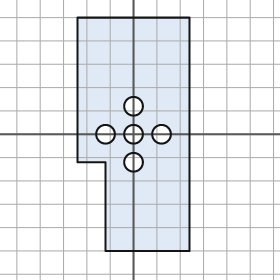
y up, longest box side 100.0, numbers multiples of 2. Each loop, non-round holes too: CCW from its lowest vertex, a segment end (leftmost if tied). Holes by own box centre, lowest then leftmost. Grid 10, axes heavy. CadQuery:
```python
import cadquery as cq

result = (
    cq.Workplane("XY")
    .moveTo(-12.0, -50.0)
    .lineTo(24.0, -50.0)
    .lineTo(24.0, 50.0)
    .lineTo(-24.0, 50.0)
    .lineTo(-24.0, -12.0)
    .lineTo(-12.0, -12.0)
    .close()
    .moveTo(0.0, -12.0)
    .circle(4.0)
    .moveTo(-12.0, 0.0)
    .circle(4.0)
    .moveTo(0.0, 0.0)
    .circle(4.0)
    .moveTo(12.0, 0.0)
    .circle(4.0)
    .moveTo(0.0, 12.0)
    .circle(4.0)
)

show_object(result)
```